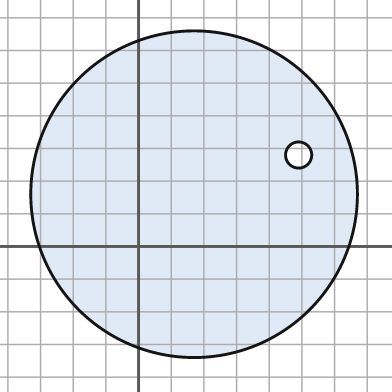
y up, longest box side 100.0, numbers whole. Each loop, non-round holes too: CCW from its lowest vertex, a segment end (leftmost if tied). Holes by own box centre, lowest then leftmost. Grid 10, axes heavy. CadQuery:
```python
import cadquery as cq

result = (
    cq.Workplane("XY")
    .moveTo(17.0, 16.0)
    .circle(50.0)
    .moveTo(49.0, 28.0)
    .circle(4.0)
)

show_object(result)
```